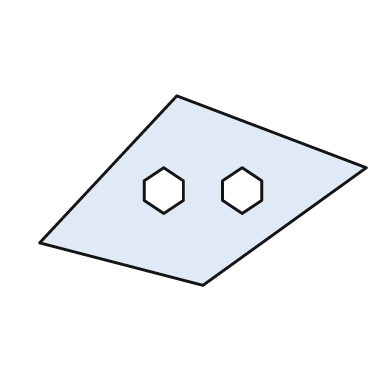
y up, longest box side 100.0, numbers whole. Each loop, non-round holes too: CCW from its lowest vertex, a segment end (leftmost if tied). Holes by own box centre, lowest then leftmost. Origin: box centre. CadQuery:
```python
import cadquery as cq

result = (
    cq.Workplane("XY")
    .moveTo(0.0, -29.0)
    .lineTo(50.0, 7.0)
    .lineTo(-8.0, 29.0)
    .lineTo(-50.0, -16.0)
    .close()
    .moveTo(-12.0, -7.0)
    .lineTo(-6.0, -3.0)
    .lineTo(-6.0, 3.0)
    .lineTo(-12.0, 7.0)
    .lineTo(-18.0, 3.0)
    .lineTo(-18.0, -3.0)
    .close()
    .moveTo(12.0, -7.0)
    .lineTo(18.0, -3.0)
    .lineTo(18.0, 3.0)
    .lineTo(12.0, 7.0)
    .lineTo(6.0, 3.0)
    .lineTo(6.0, -3.0)
    .close()
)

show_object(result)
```